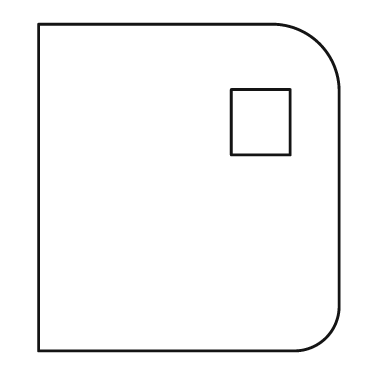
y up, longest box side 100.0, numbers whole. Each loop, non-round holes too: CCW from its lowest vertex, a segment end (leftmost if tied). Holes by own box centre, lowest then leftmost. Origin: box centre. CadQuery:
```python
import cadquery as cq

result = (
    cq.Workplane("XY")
    .moveTo(-46.0, -50.0)
    .lineTo(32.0, -50.0)
    .threePointArc((42.0, -46.0), (46.0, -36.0))
    .lineTo(46.0, 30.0)
    .threePointArc((40.0, 44.0), (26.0, 50.0))
    .lineTo(-46.0, 50.0)
    .close()
    .moveTo(13.0, 10.0)
    .lineTo(31.0, 10.0)
    .lineTo(31.0, 30.0)
    .lineTo(13.0, 30.0)
    .close()
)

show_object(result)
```